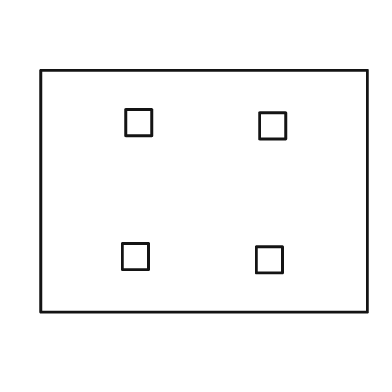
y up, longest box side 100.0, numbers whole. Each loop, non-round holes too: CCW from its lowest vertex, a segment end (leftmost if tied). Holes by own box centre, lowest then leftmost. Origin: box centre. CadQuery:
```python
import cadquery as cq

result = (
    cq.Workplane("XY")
    .moveTo(-50.0, -37.0)
    .lineTo(50.0, -37.0)
    .lineTo(50.0, 37.0)
    .lineTo(-50.0, 37.0)
    .close()
    .moveTo(16.0, -25.0)
    .lineTo(24.0, -25.0)
    .lineTo(24.0, -17.0)
    .lineTo(16.0, -17.0)
    .close()
    .moveTo(-25.0, -24.0)
    .lineTo(-17.0, -24.0)
    .lineTo(-17.0, -16.0)
    .lineTo(-25.0, -16.0)
    .close()
    .moveTo(17.0, 16.0)
    .lineTo(25.0, 16.0)
    .lineTo(25.0, 24.0)
    .lineTo(17.0, 24.0)
    .close()
    .moveTo(-24.0, 17.0)
    .lineTo(-16.0, 17.0)
    .lineTo(-16.0, 25.0)
    .lineTo(-24.0, 25.0)
    .close()
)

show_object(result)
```